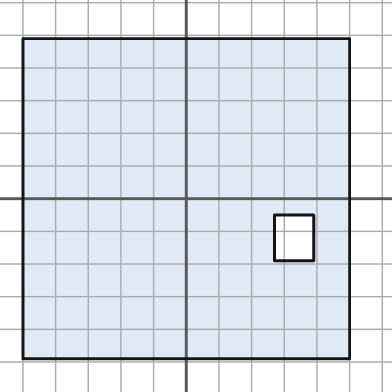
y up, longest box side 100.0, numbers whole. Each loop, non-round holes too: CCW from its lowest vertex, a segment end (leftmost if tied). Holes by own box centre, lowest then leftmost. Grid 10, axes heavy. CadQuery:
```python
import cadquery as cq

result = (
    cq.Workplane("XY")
    .moveTo(-50.0, -49.0)
    .lineTo(50.0, -49.0)
    .lineTo(50.0, 49.0)
    .lineTo(-50.0, 49.0)
    .close()
    .moveTo(27.0, -19.0)
    .lineTo(39.0, -19.0)
    .lineTo(39.0, -5.0)
    .lineTo(27.0, -5.0)
    .close()
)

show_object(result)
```